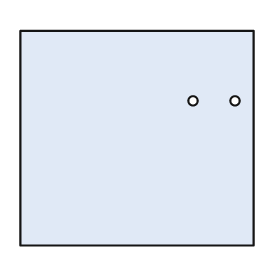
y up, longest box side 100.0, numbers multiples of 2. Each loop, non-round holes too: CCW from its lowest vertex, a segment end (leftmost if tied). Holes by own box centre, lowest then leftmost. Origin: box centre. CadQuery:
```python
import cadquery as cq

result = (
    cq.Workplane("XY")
    .moveTo(-50.0, -46.0)
    .lineTo(50.0, -46.0)
    .lineTo(50.0, 46.0)
    .lineTo(-50.0, 46.0)
    .close()
    .moveTo(24.0, 16.0)
    .circle(2.0)
    .moveTo(42.0, 16.0)
    .circle(2.0)
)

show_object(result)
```